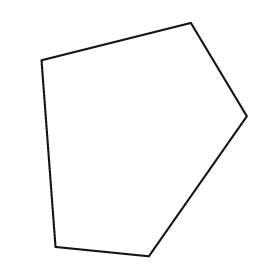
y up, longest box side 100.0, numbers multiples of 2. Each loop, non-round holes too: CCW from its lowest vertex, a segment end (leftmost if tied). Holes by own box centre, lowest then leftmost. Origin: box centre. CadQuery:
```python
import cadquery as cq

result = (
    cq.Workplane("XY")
    .moveTo(2.0, -50.0)
    .lineTo(44.0, 10.0)
    .lineTo(20.0, 50.0)
    .lineTo(-44.0, 34.0)
    .lineTo(-38.0, -46.0)
    .close()
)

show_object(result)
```